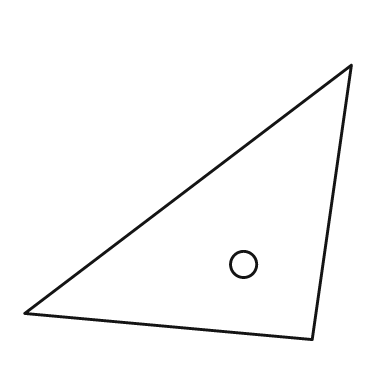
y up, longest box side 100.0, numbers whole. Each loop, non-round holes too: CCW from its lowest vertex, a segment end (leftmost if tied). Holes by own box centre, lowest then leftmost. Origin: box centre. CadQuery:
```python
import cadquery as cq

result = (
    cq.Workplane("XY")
    .moveTo(38.0, -42.0)
    .lineTo(50.0, 42.0)
    .lineTo(-50.0, -34.0)
    .close()
    .moveTo(17.0, -19.0)
    .circle(4.0)
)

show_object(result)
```